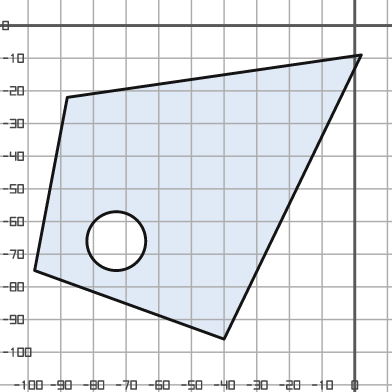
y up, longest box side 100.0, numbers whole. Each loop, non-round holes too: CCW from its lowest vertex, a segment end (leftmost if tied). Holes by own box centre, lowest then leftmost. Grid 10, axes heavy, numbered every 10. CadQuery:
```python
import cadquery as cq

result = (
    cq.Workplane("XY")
    .moveTo(-40.0, -96.0)
    .lineTo(2.0, -9.0)
    .lineTo(-88.0, -22.0)
    .lineTo(-98.0, -75.0)
    .close()
    .moveTo(-73.0, -66.0)
    .circle(9.0)
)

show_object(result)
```